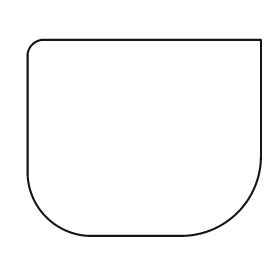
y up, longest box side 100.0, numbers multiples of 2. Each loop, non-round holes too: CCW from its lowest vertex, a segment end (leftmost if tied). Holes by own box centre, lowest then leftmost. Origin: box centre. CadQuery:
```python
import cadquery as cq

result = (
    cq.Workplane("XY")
    .moveTo(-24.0, -42.0)
    .lineTo(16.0, -42.0)
    .threePointArc((40.0, -32.0), (50.0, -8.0))
    .lineTo(50.0, 42.0)
    .lineTo(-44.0, 42.0)
    .threePointArc((-48.0, 40.0), (-50.0, 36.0))
    .lineTo(-50.0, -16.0)
    .threePointArc((-42.0, -34.0), (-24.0, -42.0))
    .close()
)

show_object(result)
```